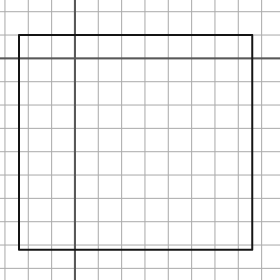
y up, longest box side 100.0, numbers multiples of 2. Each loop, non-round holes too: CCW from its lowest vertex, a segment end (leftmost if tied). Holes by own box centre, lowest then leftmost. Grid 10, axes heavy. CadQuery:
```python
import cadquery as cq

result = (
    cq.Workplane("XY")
    .moveTo(-24.0, -82.0)
    .lineTo(76.0, -82.0)
    .lineTo(76.0, 10.0)
    .lineTo(-24.0, 10.0)
    .close()
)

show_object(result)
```